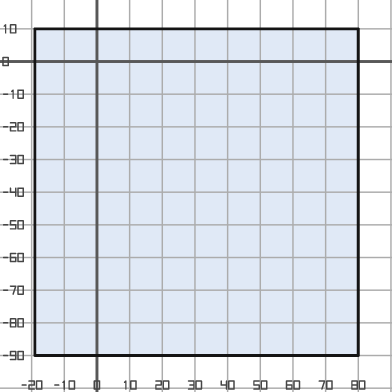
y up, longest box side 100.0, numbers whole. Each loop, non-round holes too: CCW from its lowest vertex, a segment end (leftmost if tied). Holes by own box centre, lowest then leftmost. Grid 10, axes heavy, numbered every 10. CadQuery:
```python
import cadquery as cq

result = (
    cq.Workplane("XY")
    .moveTo(-19.0, -90.0)
    .lineTo(80.0, -90.0)
    .lineTo(80.0, 10.0)
    .lineTo(-19.0, 10.0)
    .close()
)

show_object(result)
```